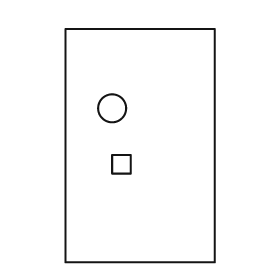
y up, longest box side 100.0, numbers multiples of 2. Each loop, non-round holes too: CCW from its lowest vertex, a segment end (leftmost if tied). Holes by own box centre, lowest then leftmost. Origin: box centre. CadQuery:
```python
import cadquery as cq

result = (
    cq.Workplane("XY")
    .moveTo(-32.0, -50.0)
    .lineTo(32.0, -50.0)
    .lineTo(32.0, 50.0)
    .lineTo(-32.0, 50.0)
    .close()
    .moveTo(-12.0, -12.0)
    .lineTo(-4.0, -12.0)
    .lineTo(-4.0, -4.0)
    .lineTo(-12.0, -4.0)
    .close()
    .moveTo(-12.0, 16.0)
    .circle(6.0)
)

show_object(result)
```